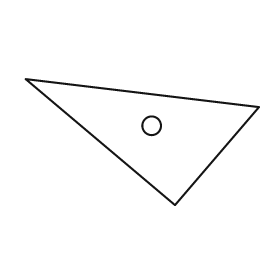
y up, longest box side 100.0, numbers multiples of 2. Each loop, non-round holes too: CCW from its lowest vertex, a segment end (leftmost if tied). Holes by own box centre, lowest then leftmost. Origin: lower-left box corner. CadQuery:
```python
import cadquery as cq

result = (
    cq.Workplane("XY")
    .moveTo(64.0, 0.0)
    .lineTo(100.0, 42.0)
    .lineTo(0.0, 54.0)
    .close()
    .moveTo(54.0, 34.0)
    .circle(4.0)
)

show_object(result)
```